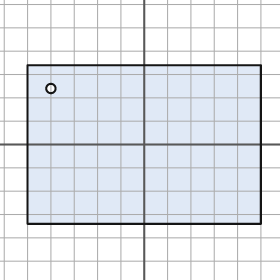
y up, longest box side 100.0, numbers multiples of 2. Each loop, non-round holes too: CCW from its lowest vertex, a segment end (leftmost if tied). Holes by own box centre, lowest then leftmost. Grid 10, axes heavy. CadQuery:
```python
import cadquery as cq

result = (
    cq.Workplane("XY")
    .moveTo(-50.0, -34.0)
    .lineTo(50.0, -34.0)
    .lineTo(50.0, 34.0)
    .lineTo(-50.0, 34.0)
    .close()
    .moveTo(-40.0, 24.0)
    .circle(2.0)
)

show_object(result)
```